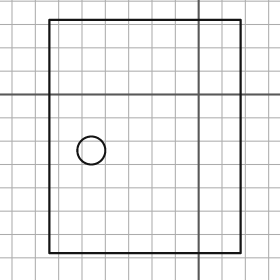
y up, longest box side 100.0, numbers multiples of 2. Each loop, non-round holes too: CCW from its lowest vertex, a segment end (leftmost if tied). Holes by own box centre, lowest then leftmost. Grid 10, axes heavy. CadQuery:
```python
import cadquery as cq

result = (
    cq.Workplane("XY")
    .moveTo(-64.0, -68.0)
    .lineTo(18.0, -68.0)
    .lineTo(18.0, 32.0)
    .lineTo(-64.0, 32.0)
    .close()
    .moveTo(-46.0, -24.0)
    .circle(6.0)
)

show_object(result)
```